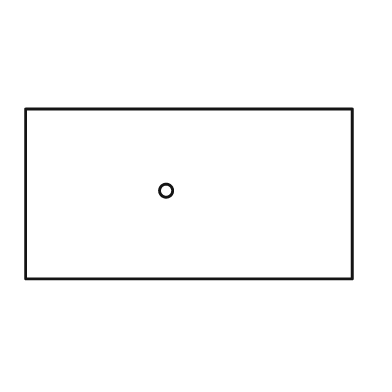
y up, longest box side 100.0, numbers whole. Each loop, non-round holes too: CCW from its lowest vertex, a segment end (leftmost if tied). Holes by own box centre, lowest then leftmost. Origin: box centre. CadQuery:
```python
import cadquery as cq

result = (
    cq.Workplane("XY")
    .moveTo(-50.0, -26.0)
    .lineTo(50.0, -26.0)
    .lineTo(50.0, 26.0)
    .lineTo(-50.0, 26.0)
    .close()
    .moveTo(-7.0, 1.0)
    .circle(2.0)
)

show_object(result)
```